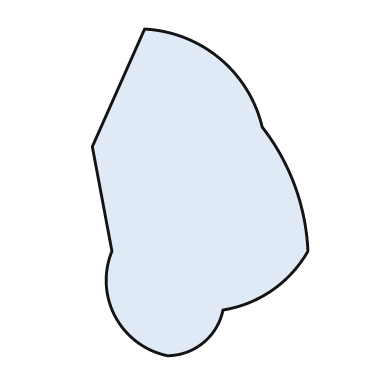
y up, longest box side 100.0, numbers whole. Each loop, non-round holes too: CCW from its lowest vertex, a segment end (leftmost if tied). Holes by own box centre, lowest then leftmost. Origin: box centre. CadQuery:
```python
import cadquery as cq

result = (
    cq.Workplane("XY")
    .moveTo(-10.0, -50.0)
    .threePointArc((1.0, -46.0), (7.0, -36.0))
    .threePointArc((22.0, -30.0), (33.0, -18.0))
    .threePointArc((29.0, 2.0), (19.0, 20.0))
    .threePointArc((6.0, 41.0), (-17.0, 50.0))
    .lineTo(-33.0, 14.0)
    .lineTo(-27.0, -18.0)
    .threePointArc((-26.0, -38.0), (-10.0, -50.0))
    .close()
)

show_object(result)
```